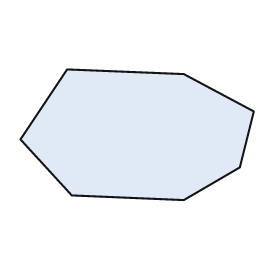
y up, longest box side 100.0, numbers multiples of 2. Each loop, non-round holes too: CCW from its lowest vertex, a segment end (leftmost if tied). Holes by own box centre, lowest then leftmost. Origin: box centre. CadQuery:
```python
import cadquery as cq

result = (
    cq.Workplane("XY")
    .moveTo(20.0, -28.0)
    .lineTo(44.0, -14.0)
    .lineTo(50.0, 10.0)
    .lineTo(20.0, 26.0)
    .lineTo(-30.0, 28.0)
    .lineTo(-50.0, -2.0)
    .lineTo(-28.0, -26.0)
    .close()
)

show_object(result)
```